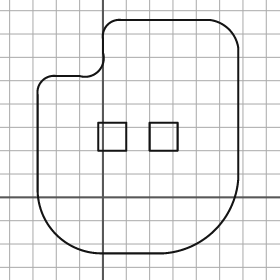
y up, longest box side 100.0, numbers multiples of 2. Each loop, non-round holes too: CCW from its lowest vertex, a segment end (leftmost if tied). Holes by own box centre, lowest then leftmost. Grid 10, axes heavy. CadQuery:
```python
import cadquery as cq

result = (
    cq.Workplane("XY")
    .moveTo(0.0, -24.0)
    .lineTo(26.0, -24.0)
    .threePointArc((48.0, -14.0), (58.0, 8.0))
    .lineTo(58.0, 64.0)
    .threePointArc((54.0, 72.0), (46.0, 76.0))
    .lineTo(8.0, 76.0)
    .threePointArc((2.0, 74.0), (0.0, 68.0))
    .lineTo(0.0, 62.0)
    .threePointArc((-2.0, 54.0), (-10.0, 52.0))
    .lineTo(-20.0, 52.0)
    .threePointArc((-26.0, 50.0), (-28.0, 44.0))
    .lineTo(-28.0, 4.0)
    .threePointArc((-20.0, -16.0), (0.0, -24.0))
    .close()
    .moveTo(-2.0, 20.0)
    .lineTo(10.0, 20.0)
    .lineTo(10.0, 32.0)
    .lineTo(-2.0, 32.0)
    .close()
    .moveTo(20.0, 20.0)
    .lineTo(32.0, 20.0)
    .lineTo(32.0, 32.0)
    .lineTo(20.0, 32.0)
    .close()
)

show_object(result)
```